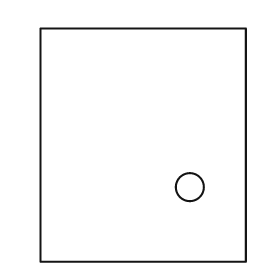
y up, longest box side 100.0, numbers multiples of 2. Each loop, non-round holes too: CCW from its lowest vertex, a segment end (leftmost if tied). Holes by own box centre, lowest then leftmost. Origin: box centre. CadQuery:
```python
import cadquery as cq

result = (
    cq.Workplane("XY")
    .moveTo(-44.0, -50.0)
    .lineTo(44.0, -50.0)
    .lineTo(44.0, 50.0)
    .lineTo(-44.0, 50.0)
    .close()
    .moveTo(20.0, -18.0)
    .circle(6.0)
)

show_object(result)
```